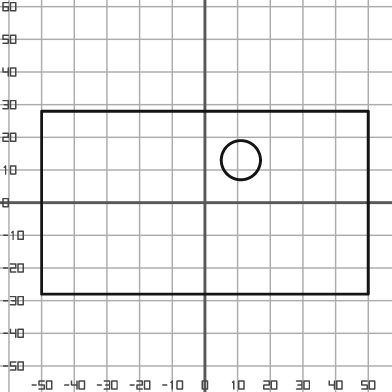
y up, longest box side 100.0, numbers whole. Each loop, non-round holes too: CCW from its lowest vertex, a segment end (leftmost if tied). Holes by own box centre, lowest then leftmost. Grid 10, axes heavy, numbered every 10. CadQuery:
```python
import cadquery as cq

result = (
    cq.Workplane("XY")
    .moveTo(-50.0, -28.0)
    .lineTo(50.0, -28.0)
    .lineTo(50.0, 28.0)
    .lineTo(-50.0, 28.0)
    .close()
    .moveTo(11.0, 13.0)
    .circle(6.0)
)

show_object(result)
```